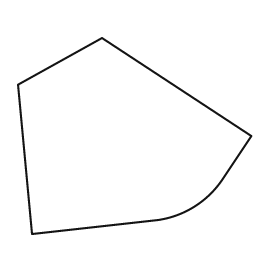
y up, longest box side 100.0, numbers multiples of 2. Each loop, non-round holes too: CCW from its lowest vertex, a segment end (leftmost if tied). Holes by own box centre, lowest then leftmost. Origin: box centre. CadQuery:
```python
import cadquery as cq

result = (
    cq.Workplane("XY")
    .moveTo(-44.0, -42.0)
    .lineTo(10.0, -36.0)
    .threePointArc((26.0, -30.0), (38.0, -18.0))
    .lineTo(50.0, 0.0)
    .lineTo(-14.0, 42.0)
    .lineTo(-50.0, 22.0)
    .close()
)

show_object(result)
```